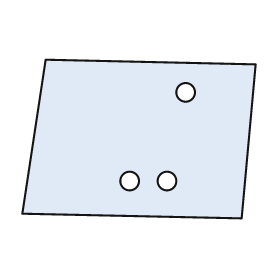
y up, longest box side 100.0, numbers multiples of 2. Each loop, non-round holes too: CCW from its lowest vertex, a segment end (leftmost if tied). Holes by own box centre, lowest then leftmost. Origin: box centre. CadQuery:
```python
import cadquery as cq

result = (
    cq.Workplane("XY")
    .moveTo(44.0, -34.0)
    .lineTo(50.0, 32.0)
    .lineTo(-40.0, 34.0)
    .lineTo(-50.0, -32.0)
    .close()
    .moveTo(-4.0, -18.0)
    .circle(4.0)
    .moveTo(12.0, -18.0)
    .circle(4.0)
    .moveTo(20.0, 20.0)
    .circle(4.0)
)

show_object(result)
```